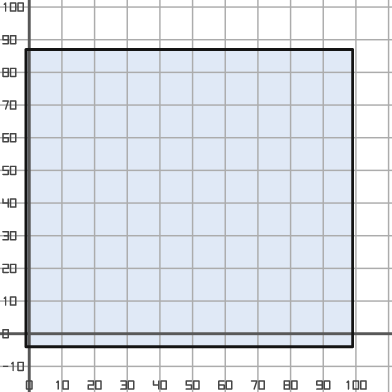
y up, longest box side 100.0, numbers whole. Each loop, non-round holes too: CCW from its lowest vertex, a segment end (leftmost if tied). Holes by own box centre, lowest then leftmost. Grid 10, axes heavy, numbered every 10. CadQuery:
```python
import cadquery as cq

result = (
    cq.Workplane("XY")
    .moveTo(-1.0, -4.0)
    .lineTo(99.0, -4.0)
    .lineTo(99.0, 87.0)
    .lineTo(-1.0, 87.0)
    .close()
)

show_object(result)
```